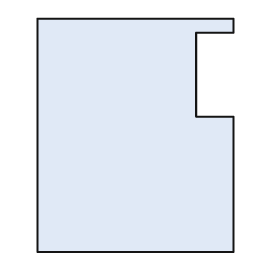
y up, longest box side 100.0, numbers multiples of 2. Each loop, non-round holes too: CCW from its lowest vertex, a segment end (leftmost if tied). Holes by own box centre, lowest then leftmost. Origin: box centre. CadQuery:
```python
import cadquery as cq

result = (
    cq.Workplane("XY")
    .moveTo(-42.0, -50.0)
    .lineTo(42.0, -50.0)
    .lineTo(42.0, 8.0)
    .lineTo(26.0, 8.0)
    .lineTo(26.0, 44.0)
    .lineTo(42.0, 44.0)
    .lineTo(42.0, 50.0)
    .lineTo(-42.0, 50.0)
    .close()
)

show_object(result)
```